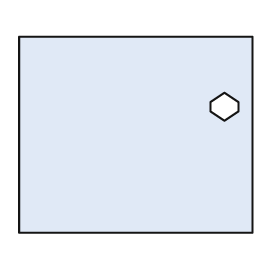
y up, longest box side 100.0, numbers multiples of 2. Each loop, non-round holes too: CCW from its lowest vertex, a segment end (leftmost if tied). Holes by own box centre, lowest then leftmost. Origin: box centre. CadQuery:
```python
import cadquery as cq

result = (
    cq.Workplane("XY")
    .moveTo(-50.0, -42.0)
    .lineTo(50.0, -42.0)
    .lineTo(50.0, 42.0)
    .lineTo(-50.0, 42.0)
    .close()
    .moveTo(38.0, 6.0)
    .lineTo(44.0, 10.0)
    .lineTo(44.0, 14.0)
    .lineTo(38.0, 18.0)
    .lineTo(32.0, 14.0)
    .lineTo(32.0, 10.0)
    .close()
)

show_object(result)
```